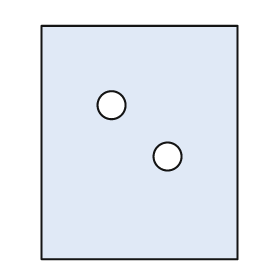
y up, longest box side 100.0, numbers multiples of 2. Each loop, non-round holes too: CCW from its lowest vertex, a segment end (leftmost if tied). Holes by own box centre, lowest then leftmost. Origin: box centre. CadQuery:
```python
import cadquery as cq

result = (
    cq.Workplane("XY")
    .moveTo(-42.0, -50.0)
    .lineTo(42.0, -50.0)
    .lineTo(42.0, 50.0)
    .lineTo(-42.0, 50.0)
    .close()
    .moveTo(12.0, -6.0)
    .circle(6.0)
    .moveTo(-12.0, 16.0)
    .circle(6.0)
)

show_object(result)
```